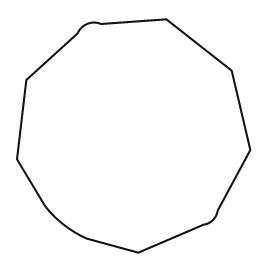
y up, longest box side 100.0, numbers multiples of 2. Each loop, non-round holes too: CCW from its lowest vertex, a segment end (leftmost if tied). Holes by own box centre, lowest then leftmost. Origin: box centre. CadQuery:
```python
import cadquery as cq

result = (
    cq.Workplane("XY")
    .moveTo(2.0, -50.0)
    .lineTo(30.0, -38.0)
    .threePointArc((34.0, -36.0), (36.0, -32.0))
    .lineTo(50.0, -6.0)
    .lineTo(42.0, 28.0)
    .lineTo(14.0, 50.0)
    .lineTo(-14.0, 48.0)
    .threePointArc((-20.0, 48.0), (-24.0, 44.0))
    .lineTo(-46.0, 24.0)
    .lineTo(-50.0, -10.0)
    .lineTo(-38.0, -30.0)
    .threePointArc((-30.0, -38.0), (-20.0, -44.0))
    .close()
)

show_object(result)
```